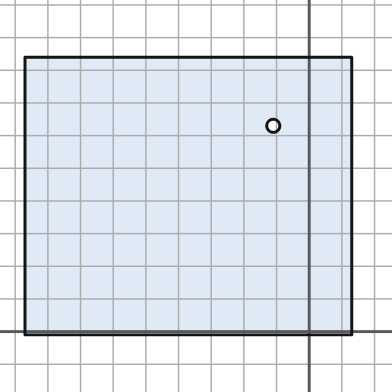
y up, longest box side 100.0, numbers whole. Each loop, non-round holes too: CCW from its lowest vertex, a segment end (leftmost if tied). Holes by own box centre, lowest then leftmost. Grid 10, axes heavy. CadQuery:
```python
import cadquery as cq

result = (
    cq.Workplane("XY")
    .moveTo(-87.0, -1.0)
    .lineTo(13.0, -1.0)
    .lineTo(13.0, 84.0)
    .lineTo(-87.0, 84.0)
    .close()
    .moveTo(-11.0, 63.0)
    .circle(2.0)
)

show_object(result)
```